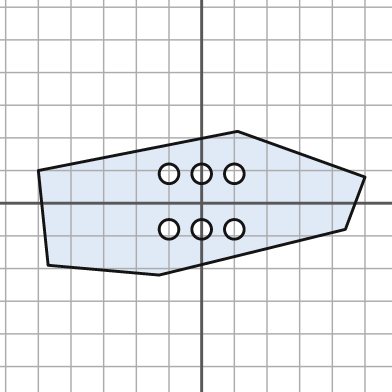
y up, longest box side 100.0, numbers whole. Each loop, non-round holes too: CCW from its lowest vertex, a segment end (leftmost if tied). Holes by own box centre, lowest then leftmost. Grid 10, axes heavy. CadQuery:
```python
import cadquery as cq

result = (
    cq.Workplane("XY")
    .moveTo(-13.0, -22.0)
    .lineTo(44.0, -8.0)
    .lineTo(50.0, 8.0)
    .lineTo(11.0, 22.0)
    .lineTo(-50.0, 10.0)
    .lineTo(-47.0, -19.0)
    .close()
    .moveTo(-10.0, -8.0)
    .circle(3.0)
    .moveTo(0.0, -8.0)
    .circle(3.0)
    .moveTo(10.0, -8.0)
    .circle(3.0)
    .moveTo(-10.0, 9.0)
    .circle(3.0)
    .moveTo(0.0, 9.0)
    .circle(3.0)
    .moveTo(10.0, 9.0)
    .circle(3.0)
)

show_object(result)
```